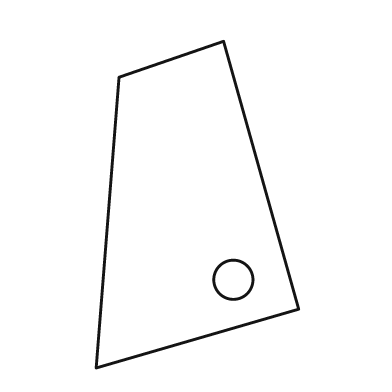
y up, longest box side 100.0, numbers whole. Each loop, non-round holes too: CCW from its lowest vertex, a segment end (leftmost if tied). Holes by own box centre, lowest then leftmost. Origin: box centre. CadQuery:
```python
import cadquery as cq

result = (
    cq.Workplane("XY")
    .moveTo(-31.0, -50.0)
    .lineTo(31.0, -32.0)
    .lineTo(8.0, 50.0)
    .lineTo(-24.0, 39.0)
    .close()
    .moveTo(11.0, -23.0)
    .circle(6.0)
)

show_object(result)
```